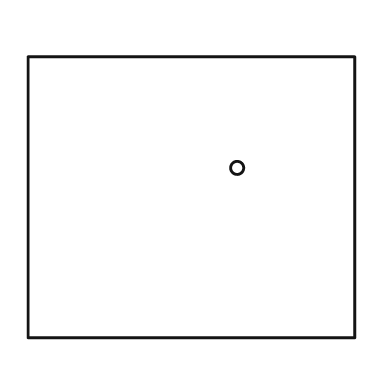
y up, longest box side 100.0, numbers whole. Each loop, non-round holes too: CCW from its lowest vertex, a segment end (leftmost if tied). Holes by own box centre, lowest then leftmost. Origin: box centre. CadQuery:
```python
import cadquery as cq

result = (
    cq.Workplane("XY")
    .moveTo(-50.0, -43.0)
    .lineTo(50.0, -43.0)
    .lineTo(50.0, 43.0)
    .lineTo(-50.0, 43.0)
    .close()
    .moveTo(14.0, 9.0)
    .circle(2.0)
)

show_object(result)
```